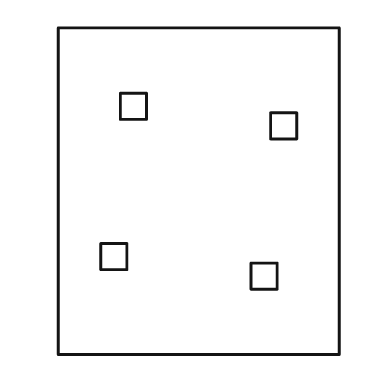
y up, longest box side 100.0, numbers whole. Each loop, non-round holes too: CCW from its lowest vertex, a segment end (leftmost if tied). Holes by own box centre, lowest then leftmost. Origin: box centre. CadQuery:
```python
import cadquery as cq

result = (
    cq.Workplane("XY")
    .moveTo(-43.0, -50.0)
    .lineTo(43.0, -50.0)
    .lineTo(43.0, 50.0)
    .lineTo(-43.0, 50.0)
    .close()
    .moveTo(16.0, -30.0)
    .lineTo(24.0, -30.0)
    .lineTo(24.0, -22.0)
    .lineTo(16.0, -22.0)
    .close()
    .moveTo(-30.0, -24.0)
    .lineTo(-22.0, -24.0)
    .lineTo(-22.0, -16.0)
    .lineTo(-30.0, -16.0)
    .close()
    .moveTo(22.0, 16.0)
    .lineTo(30.0, 16.0)
    .lineTo(30.0, 24.0)
    .lineTo(22.0, 24.0)
    .close()
    .moveTo(-24.0, 22.0)
    .lineTo(-16.0, 22.0)
    .lineTo(-16.0, 30.0)
    .lineTo(-24.0, 30.0)
    .close()
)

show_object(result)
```